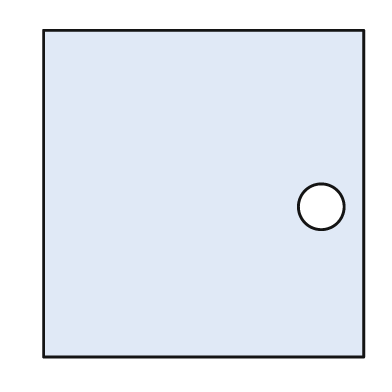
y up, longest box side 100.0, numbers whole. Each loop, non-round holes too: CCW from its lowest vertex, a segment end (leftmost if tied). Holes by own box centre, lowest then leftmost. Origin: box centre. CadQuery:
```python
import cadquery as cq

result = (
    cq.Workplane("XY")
    .moveTo(-49.0, -50.0)
    .lineTo(49.0, -50.0)
    .lineTo(49.0, 50.0)
    .lineTo(-49.0, 50.0)
    .close()
    .moveTo(36.0, -4.0)
    .circle(7.0)
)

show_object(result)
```